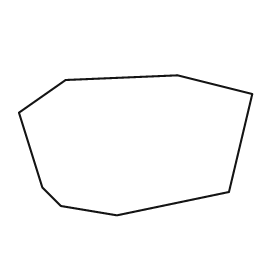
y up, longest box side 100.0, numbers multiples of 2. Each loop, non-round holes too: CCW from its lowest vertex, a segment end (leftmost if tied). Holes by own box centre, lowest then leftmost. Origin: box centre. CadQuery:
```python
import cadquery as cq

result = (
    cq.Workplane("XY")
    .moveTo(-8.0, -30.0)
    .lineTo(40.0, -20.0)
    .lineTo(50.0, 22.0)
    .lineTo(18.0, 30.0)
    .lineTo(-30.0, 28.0)
    .lineTo(-50.0, 14.0)
    .lineTo(-40.0, -18.0)
    .lineTo(-32.0, -26.0)
    .close()
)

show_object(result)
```